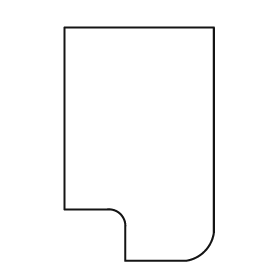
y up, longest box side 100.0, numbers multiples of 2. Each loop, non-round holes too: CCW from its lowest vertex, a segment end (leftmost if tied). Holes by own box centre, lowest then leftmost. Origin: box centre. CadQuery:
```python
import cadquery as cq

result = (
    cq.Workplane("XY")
    .moveTo(-6.0, -50.0)
    .lineTo(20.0, -50.0)
    .threePointArc((28.0, -46.0), (32.0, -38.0))
    .lineTo(32.0, 50.0)
    .lineTo(-32.0, 50.0)
    .lineTo(-32.0, -28.0)
    .lineTo(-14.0, -28.0)
    .threePointArc((-8.0, -30.0), (-6.0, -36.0))
    .close()
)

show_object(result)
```